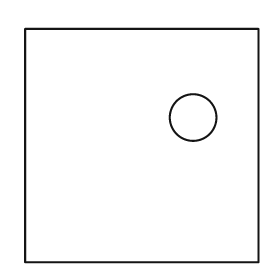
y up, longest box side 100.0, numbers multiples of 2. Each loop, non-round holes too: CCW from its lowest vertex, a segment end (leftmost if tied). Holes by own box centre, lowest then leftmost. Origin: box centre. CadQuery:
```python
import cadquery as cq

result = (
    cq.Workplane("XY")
    .moveTo(-50.0, -50.0)
    .lineTo(50.0, -50.0)
    .lineTo(50.0, 50.0)
    .lineTo(-50.0, 50.0)
    .close()
    .moveTo(22.0, 12.0)
    .circle(10.0)
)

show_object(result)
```